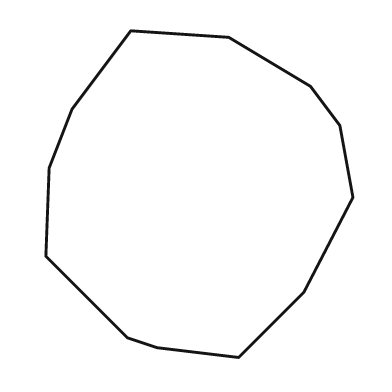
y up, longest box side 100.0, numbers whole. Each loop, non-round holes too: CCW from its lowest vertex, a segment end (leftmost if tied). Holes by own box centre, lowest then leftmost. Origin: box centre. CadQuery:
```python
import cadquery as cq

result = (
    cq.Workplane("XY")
    .moveTo(12.0, -50.0)
    .lineTo(32.0, -30.0)
    .lineTo(47.0, -1.0)
    .lineTo(43.0, 21.0)
    .lineTo(34.0, 33.0)
    .lineTo(9.0, 48.0)
    .lineTo(-21.0, 50.0)
    .lineTo(-39.0, 26.0)
    .lineTo(-46.0, 8.0)
    .lineTo(-47.0, -19.0)
    .lineTo(-22.0, -44.0)
    .lineTo(-13.0, -47.0)
    .close()
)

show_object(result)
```